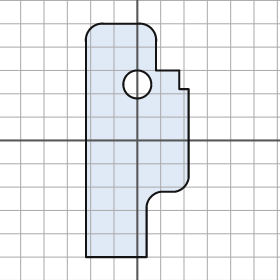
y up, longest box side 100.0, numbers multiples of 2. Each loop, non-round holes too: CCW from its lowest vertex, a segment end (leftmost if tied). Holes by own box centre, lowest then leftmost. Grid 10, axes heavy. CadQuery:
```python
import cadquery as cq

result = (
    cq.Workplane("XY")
    .moveTo(-22.0, -50.0)
    .lineTo(4.0, -50.0)
    .lineTo(4.0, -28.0)
    .threePointArc((6.0, -24.0), (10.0, -22.0))
    .lineTo(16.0, -22.0)
    .threePointArc((20.0, -20.0), (22.0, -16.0))
    .lineTo(22.0, 22.0)
    .lineTo(18.0, 22.0)
    .lineTo(18.0, 30.0)
    .lineTo(8.0, 30.0)
    .lineTo(8.0, 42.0)
    .threePointArc((6.0, 48.0), (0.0, 50.0))
    .lineTo(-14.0, 50.0)
    .threePointArc((-20.0, 48.0), (-22.0, 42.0))
    .close()
    .moveTo(0.0, 24.0)
    .circle(6.0)
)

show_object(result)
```